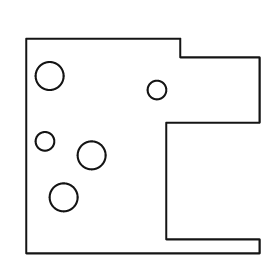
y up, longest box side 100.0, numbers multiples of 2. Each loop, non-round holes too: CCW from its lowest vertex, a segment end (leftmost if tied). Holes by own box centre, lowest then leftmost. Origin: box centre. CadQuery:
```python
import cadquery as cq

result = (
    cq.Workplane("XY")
    .moveTo(-50.0, -46.0)
    .lineTo(50.0, -46.0)
    .lineTo(50.0, -40.0)
    .lineTo(10.0, -40.0)
    .lineTo(10.0, 10.0)
    .lineTo(50.0, 10.0)
    .lineTo(50.0, 38.0)
    .lineTo(16.0, 38.0)
    .lineTo(16.0, 46.0)
    .lineTo(-50.0, 46.0)
    .close()
    .moveTo(-34.0, -22.0)
    .circle(6.0)
    .moveTo(-22.0, -4.0)
    .circle(6.0)
    .moveTo(-42.0, 2.0)
    .circle(4.0)
    .moveTo(6.0, 24.0)
    .circle(4.0)
    .moveTo(-40.0, 30.0)
    .circle(6.0)
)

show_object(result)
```